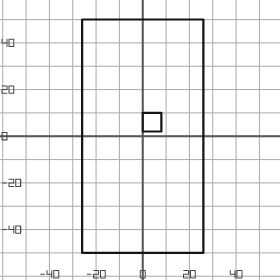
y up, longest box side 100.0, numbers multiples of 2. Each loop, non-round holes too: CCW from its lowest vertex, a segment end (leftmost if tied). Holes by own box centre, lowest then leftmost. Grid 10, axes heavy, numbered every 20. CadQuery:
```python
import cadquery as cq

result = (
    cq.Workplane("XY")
    .moveTo(-26.0, -50.0)
    .lineTo(26.0, -50.0)
    .lineTo(26.0, 50.0)
    .lineTo(-26.0, 50.0)
    .close()
    .moveTo(0.0, 2.0)
    .lineTo(8.0, 2.0)
    .lineTo(8.0, 10.0)
    .lineTo(0.0, 10.0)
    .close()
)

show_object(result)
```